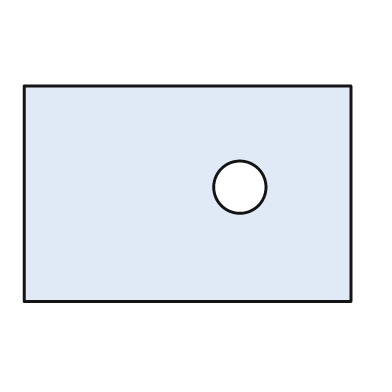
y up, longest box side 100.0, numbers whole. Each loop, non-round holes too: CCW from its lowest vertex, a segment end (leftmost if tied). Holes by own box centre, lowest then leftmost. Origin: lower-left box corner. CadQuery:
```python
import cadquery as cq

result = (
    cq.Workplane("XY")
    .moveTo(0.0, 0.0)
    .lineTo(100.0, 0.0)
    .lineTo(100.0, 66.0)
    .lineTo(0.0, 66.0)
    .close()
    .moveTo(66.0, 35.0)
    .circle(8.0)
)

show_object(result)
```